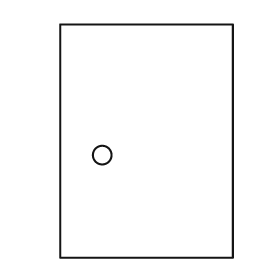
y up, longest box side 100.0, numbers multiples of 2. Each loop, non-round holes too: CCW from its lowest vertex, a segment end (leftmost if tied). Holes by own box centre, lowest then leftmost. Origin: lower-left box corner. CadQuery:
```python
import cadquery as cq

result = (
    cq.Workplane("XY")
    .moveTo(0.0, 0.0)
    .lineTo(74.0, 0.0)
    .lineTo(74.0, 100.0)
    .lineTo(0.0, 100.0)
    .close()
    .moveTo(18.0, 44.0)
    .circle(4.0)
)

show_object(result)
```